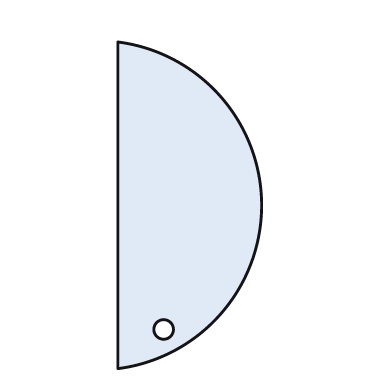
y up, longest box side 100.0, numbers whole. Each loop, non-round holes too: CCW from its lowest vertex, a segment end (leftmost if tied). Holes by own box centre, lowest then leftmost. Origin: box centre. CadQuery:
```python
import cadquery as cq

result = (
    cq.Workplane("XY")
    .moveTo(-22.0, -50.0)
    .threePointArc((22.0, 0.0), (-22.0, 50.0))
    .close()
    .moveTo(-8.0, -38.0)
    .circle(3.0)
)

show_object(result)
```